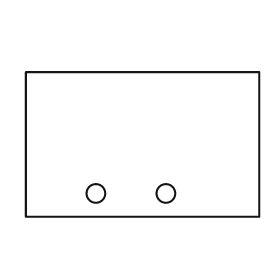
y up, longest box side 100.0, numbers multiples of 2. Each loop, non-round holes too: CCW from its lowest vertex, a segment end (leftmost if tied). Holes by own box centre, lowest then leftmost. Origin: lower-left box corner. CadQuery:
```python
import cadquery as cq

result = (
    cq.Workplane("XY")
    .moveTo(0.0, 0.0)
    .lineTo(100.0, 0.0)
    .lineTo(100.0, 62.0)
    .lineTo(0.0, 62.0)
    .close()
    .moveTo(30.0, 10.0)
    .circle(4.0)
    .moveTo(60.0, 10.0)
    .circle(4.0)
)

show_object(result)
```